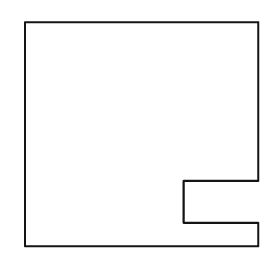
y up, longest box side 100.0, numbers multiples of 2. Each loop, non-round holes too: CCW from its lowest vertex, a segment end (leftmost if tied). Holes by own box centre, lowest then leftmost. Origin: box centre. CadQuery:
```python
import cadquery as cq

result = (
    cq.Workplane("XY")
    .moveTo(-50.0, -48.0)
    .lineTo(50.0, -48.0)
    .lineTo(50.0, -38.0)
    .lineTo(18.0, -38.0)
    .lineTo(18.0, -20.0)
    .lineTo(50.0, -20.0)
    .lineTo(50.0, 48.0)
    .lineTo(-50.0, 48.0)
    .close()
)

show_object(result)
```